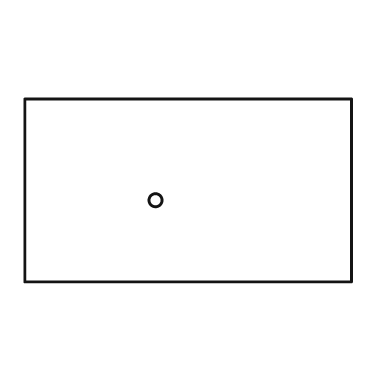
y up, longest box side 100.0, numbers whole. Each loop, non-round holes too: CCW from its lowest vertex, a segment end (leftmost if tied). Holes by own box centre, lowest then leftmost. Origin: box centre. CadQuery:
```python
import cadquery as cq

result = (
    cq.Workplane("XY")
    .moveTo(-50.0, -28.0)
    .lineTo(50.0, -28.0)
    .lineTo(50.0, 28.0)
    .lineTo(-50.0, 28.0)
    .close()
    .moveTo(-10.0, -3.0)
    .circle(2.0)
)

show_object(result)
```